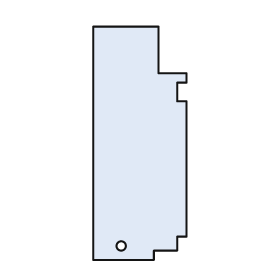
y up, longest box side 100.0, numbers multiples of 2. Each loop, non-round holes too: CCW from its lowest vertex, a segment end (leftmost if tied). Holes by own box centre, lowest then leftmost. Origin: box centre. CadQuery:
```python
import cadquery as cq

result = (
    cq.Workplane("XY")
    .moveTo(-20.0, -50.0)
    .lineTo(6.0, -50.0)
    .lineTo(6.0, -46.0)
    .lineTo(16.0, -46.0)
    .lineTo(16.0, -40.0)
    .lineTo(20.0, -40.0)
    .lineTo(20.0, 18.0)
    .lineTo(16.0, 18.0)
    .lineTo(16.0, 26.0)
    .lineTo(20.0, 26.0)
    .lineTo(20.0, 30.0)
    .lineTo(8.0, 30.0)
    .lineTo(8.0, 50.0)
    .lineTo(-20.0, 50.0)
    .close()
    .moveTo(-8.0, -44.0)
    .circle(2.0)
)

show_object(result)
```